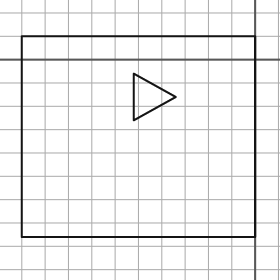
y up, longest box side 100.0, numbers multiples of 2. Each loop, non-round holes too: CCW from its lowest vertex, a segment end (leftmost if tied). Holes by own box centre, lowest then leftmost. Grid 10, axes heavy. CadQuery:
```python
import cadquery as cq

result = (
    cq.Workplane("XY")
    .moveTo(-100.0, -76.0)
    .lineTo(0.0, -76.0)
    .lineTo(0.0, 10.0)
    .lineTo(-100.0, 10.0)
    .close()
    .moveTo(-52.0, -26.0)
    .lineTo(-34.0, -16.0)
    .lineTo(-52.0, -6.0)
    .close()
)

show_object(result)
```